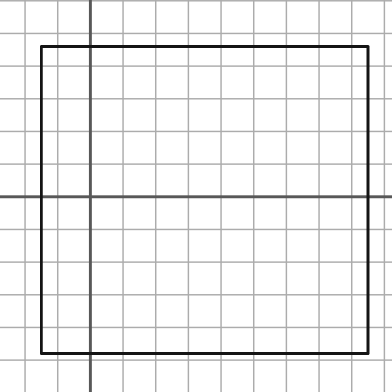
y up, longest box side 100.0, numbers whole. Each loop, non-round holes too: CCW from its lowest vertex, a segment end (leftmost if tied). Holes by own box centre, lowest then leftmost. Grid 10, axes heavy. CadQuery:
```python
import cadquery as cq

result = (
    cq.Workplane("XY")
    .moveTo(-15.0, -48.0)
    .lineTo(85.0, -48.0)
    .lineTo(85.0, 46.0)
    .lineTo(-15.0, 46.0)
    .close()
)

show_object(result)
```